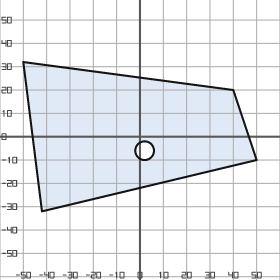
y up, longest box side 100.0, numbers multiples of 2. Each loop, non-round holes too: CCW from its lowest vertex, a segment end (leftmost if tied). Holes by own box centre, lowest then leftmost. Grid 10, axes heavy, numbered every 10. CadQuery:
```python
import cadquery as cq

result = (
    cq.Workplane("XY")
    .moveTo(-42.0, -32.0)
    .lineTo(50.0, -10.0)
    .lineTo(40.0, 20.0)
    .lineTo(-50.0, 32.0)
    .close()
    .moveTo(2.0, -6.0)
    .circle(4.0)
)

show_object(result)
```